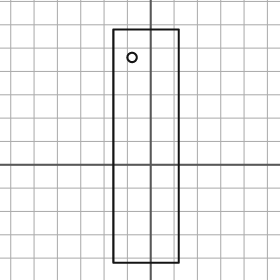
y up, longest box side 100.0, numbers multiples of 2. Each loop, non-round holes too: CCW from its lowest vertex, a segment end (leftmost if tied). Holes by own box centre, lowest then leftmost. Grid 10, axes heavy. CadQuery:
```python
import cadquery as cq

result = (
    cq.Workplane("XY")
    .moveTo(-16.0, -42.0)
    .lineTo(12.0, -42.0)
    .lineTo(12.0, 58.0)
    .lineTo(-16.0, 58.0)
    .close()
    .moveTo(-8.0, 46.0)
    .circle(2.0)
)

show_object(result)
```